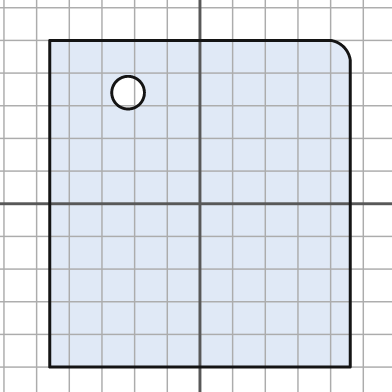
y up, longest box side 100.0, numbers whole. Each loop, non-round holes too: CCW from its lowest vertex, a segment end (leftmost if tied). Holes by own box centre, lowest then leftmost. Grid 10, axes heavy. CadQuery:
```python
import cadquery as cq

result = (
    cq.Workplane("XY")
    .moveTo(-46.0, -50.0)
    .lineTo(46.0, -50.0)
    .lineTo(46.0, 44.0)
    .threePointArc((44.0, 48.0), (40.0, 50.0))
    .lineTo(-46.0, 50.0)
    .close()
    .moveTo(-22.0, 34.0)
    .circle(5.0)
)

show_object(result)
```